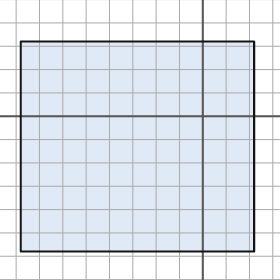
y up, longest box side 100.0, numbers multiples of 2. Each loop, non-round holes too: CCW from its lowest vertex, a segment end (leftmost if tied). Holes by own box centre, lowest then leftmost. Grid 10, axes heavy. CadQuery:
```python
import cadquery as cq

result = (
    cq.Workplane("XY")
    .moveTo(-78.0, -58.0)
    .lineTo(22.0, -58.0)
    .lineTo(22.0, 32.0)
    .lineTo(-78.0, 32.0)
    .close()
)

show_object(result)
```